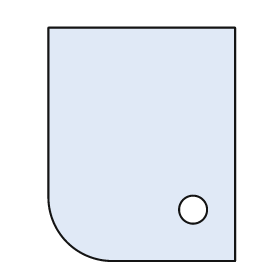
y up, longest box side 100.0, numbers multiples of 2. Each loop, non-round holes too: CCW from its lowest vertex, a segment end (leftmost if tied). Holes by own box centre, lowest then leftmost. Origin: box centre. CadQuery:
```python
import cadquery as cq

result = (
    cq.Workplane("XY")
    .moveTo(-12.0, -50.0)
    .lineTo(40.0, -50.0)
    .lineTo(40.0, 50.0)
    .lineTo(-40.0, 50.0)
    .lineTo(-40.0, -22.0)
    .threePointArc((-32.0, -42.0), (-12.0, -50.0))
    .close()
    .moveTo(22.0, -28.0)
    .circle(6.0)
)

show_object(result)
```